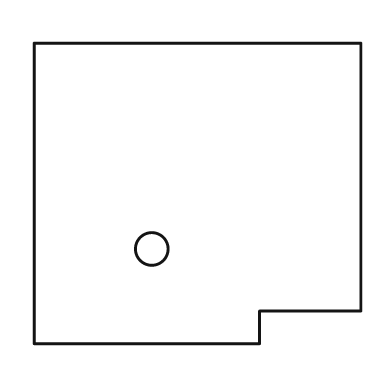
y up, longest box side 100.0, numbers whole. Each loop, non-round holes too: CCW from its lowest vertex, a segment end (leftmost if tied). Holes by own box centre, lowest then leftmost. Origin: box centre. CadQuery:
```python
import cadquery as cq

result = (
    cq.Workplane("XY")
    .moveTo(-50.0, -46.0)
    .lineTo(19.0, -46.0)
    .lineTo(19.0, -36.0)
    .lineTo(50.0, -36.0)
    .lineTo(50.0, 46.0)
    .lineTo(-50.0, 46.0)
    .close()
    .moveTo(-14.0, -17.0)
    .circle(5.0)
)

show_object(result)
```